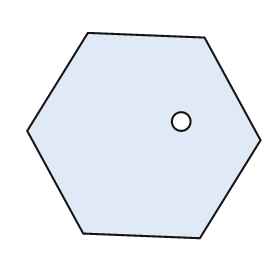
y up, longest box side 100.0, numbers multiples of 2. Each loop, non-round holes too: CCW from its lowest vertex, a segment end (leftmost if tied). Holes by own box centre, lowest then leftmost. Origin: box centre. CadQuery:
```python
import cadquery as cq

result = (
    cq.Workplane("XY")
    .moveTo(24.0, -44.0)
    .lineTo(50.0, -2.0)
    .lineTo(26.0, 42.0)
    .lineTo(-24.0, 44.0)
    .lineTo(-50.0, 2.0)
    .lineTo(-26.0, -42.0)
    .close()
    .moveTo(16.0, 6.0)
    .circle(4.0)
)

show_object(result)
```